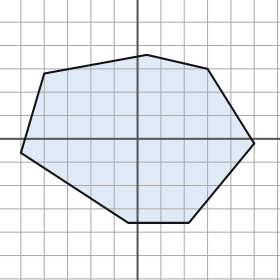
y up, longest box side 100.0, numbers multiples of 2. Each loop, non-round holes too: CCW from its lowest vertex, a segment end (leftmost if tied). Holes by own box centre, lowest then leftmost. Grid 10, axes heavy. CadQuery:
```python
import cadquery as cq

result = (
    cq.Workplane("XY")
    .moveTo(-4.0, -36.0)
    .lineTo(22.0, -36.0)
    .lineTo(50.0, -2.0)
    .lineTo(30.0, 30.0)
    .lineTo(4.0, 36.0)
    .lineTo(-40.0, 28.0)
    .lineTo(-50.0, -6.0)
    .close()
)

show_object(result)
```